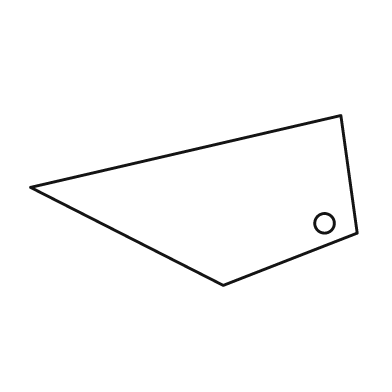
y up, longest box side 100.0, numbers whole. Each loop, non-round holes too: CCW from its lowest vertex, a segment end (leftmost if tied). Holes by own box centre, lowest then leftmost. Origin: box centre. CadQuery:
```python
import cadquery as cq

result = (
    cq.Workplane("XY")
    .moveTo(9.0, -26.0)
    .lineTo(50.0, -10.0)
    .lineTo(45.0, 26.0)
    .lineTo(-50.0, 4.0)
    .close()
    .moveTo(40.0, -7.0)
    .circle(3.0)
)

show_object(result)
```